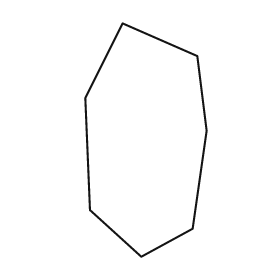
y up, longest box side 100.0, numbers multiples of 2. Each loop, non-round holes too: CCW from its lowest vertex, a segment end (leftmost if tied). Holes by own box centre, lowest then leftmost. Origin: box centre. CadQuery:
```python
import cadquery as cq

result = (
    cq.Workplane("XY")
    .moveTo(-2.0, -50.0)
    .lineTo(20.0, -38.0)
    .lineTo(26.0, 4.0)
    .lineTo(22.0, 36.0)
    .lineTo(-10.0, 50.0)
    .lineTo(-26.0, 18.0)
    .lineTo(-24.0, -30.0)
    .close()
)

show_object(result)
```